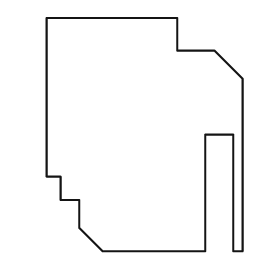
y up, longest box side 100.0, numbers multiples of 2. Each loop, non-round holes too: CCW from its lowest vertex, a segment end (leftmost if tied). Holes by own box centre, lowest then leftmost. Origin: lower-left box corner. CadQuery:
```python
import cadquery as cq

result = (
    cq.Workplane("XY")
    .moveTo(24.0, 0.0)
    .lineTo(68.0, 0.0)
    .lineTo(68.0, 50.0)
    .lineTo(80.0, 50.0)
    .lineTo(80.0, 0.0)
    .lineTo(84.0, 0.0)
    .lineTo(84.0, 74.0)
    .lineTo(72.0, 86.0)
    .lineTo(56.0, 86.0)
    .lineTo(56.0, 100.0)
    .lineTo(0.0, 100.0)
    .lineTo(0.0, 32.0)
    .lineTo(6.0, 32.0)
    .lineTo(6.0, 22.0)
    .lineTo(14.0, 22.0)
    .lineTo(14.0, 10.0)
    .close()
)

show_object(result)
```